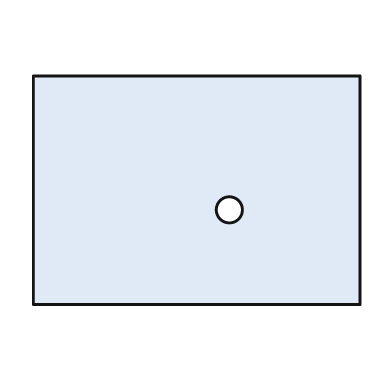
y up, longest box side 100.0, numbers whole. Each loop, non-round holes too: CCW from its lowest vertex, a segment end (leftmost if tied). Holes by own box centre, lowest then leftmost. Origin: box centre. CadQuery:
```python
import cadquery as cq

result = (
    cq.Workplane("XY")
    .moveTo(-50.0, -35.0)
    .lineTo(50.0, -35.0)
    .lineTo(50.0, 35.0)
    .lineTo(-50.0, 35.0)
    .close()
    .moveTo(10.0, -6.0)
    .circle(4.0)
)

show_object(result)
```